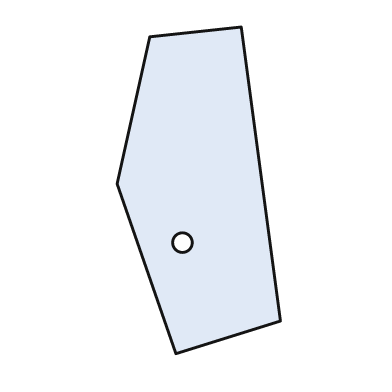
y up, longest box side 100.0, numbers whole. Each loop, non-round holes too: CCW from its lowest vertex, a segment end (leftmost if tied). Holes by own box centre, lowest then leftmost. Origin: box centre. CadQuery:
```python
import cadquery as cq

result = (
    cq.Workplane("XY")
    .moveTo(-7.0, -50.0)
    .lineTo(25.0, -40.0)
    .lineTo(13.0, 50.0)
    .lineTo(-15.0, 47.0)
    .lineTo(-25.0, 2.0)
    .close()
    .moveTo(-5.0, -16.0)
    .circle(3.0)
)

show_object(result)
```